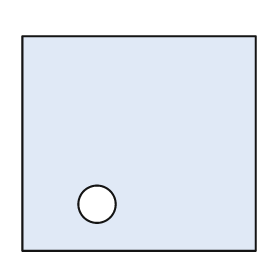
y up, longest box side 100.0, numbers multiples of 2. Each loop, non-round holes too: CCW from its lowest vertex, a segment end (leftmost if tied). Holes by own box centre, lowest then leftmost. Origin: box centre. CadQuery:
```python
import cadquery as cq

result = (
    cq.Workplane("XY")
    .moveTo(-50.0, -46.0)
    .lineTo(50.0, -46.0)
    .lineTo(50.0, 46.0)
    .lineTo(-50.0, 46.0)
    .close()
    .moveTo(-18.0, -26.0)
    .circle(8.0)
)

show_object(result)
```